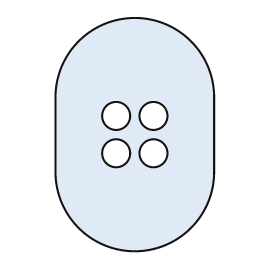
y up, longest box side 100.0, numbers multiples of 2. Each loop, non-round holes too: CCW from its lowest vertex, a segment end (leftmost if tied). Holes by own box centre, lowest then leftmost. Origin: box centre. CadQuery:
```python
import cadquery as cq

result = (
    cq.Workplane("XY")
    .moveTo(-34.0, -16.0)
    .threePointArc((0.0, -50.0), (34.0, -16.0))
    .lineTo(34.0, 16.0)
    .threePointArc((0.0, 50.0), (-34.0, 16.0))
    .close()
    .moveTo(-8.0, -8.0)
    .circle(6.0)
    .moveTo(8.0, -8.0)
    .circle(6.0)
    .moveTo(-8.0, 8.0)
    .circle(6.0)
    .moveTo(8.0, 8.0)
    .circle(6.0)
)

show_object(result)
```